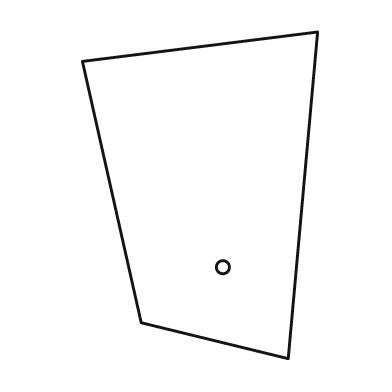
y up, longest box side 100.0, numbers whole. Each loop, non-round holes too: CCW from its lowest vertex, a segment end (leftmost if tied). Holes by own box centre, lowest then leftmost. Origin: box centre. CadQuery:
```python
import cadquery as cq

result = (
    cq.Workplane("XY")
    .moveTo(27.0, -50.0)
    .lineTo(36.0, 50.0)
    .lineTo(-36.0, 41.0)
    .lineTo(-18.0, -39.0)
    .close()
    .moveTo(7.0, -22.0)
    .circle(2.0)
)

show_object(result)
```